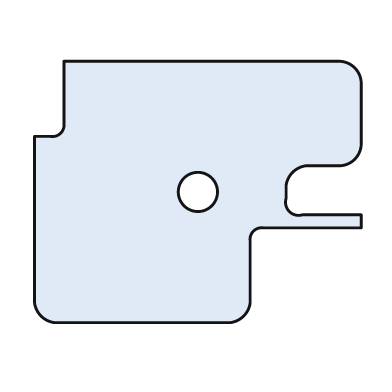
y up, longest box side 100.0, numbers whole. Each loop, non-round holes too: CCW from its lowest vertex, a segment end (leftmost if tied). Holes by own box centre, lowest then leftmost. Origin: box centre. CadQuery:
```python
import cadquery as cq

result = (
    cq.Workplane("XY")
    .moveTo(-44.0, -40.0)
    .lineTo(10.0, -40.0)
    .threePointArc((14.0, -38.0), (16.0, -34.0))
    .lineTo(16.0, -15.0)
    .threePointArc((17.0, -12.0), (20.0, -11.0))
    .lineTo(50.0, -11.0)
    .lineTo(50.0, -7.0)
    .lineTo(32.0, -7.0)
    .threePointArc((28.0, -6.0), (27.0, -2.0))
    .lineTo(27.0, 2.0)
    .threePointArc((29.0, 6.0), (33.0, 8.0))
    .lineTo(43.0, 8.0)
    .threePointArc((48.0, 10.0), (50.0, 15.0))
    .lineTo(50.0, 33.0)
    .threePointArc((48.0, 38.0), (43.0, 40.0))
    .lineTo(-41.0, 40.0)
    .lineTo(-41.0, 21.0)
    .threePointArc((-42.0, 18.0), (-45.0, 17.0))
    .lineTo(-50.0, 17.0)
    .lineTo(-50.0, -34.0)
    .threePointArc((-48.0, -38.0), (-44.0, -40.0))
    .close()
    .moveTo(0.0, 0.0)
    .circle(6.0)
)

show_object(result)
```